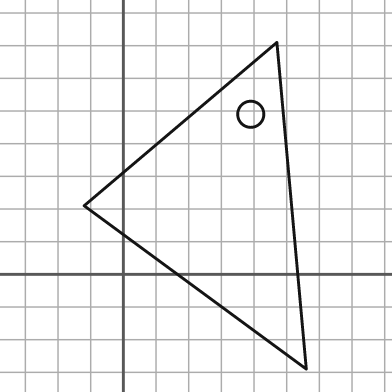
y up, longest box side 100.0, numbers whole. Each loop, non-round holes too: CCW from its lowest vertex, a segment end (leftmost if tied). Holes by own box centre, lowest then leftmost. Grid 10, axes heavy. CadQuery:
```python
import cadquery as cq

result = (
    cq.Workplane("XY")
    .moveTo(56.0, -29.0)
    .lineTo(47.0, 71.0)
    .lineTo(-12.0, 21.0)
    .close()
    .moveTo(39.0, 49.0)
    .circle(4.0)
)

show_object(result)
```